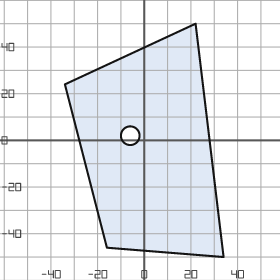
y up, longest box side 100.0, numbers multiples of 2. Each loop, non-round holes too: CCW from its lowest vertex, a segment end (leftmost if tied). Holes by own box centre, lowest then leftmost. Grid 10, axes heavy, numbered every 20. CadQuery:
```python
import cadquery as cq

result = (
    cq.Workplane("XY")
    .moveTo(34.0, -50.0)
    .lineTo(22.0, 50.0)
    .lineTo(-34.0, 24.0)
    .lineTo(-16.0, -46.0)
    .close()
    .moveTo(-6.0, 2.0)
    .circle(4.0)
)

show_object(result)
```